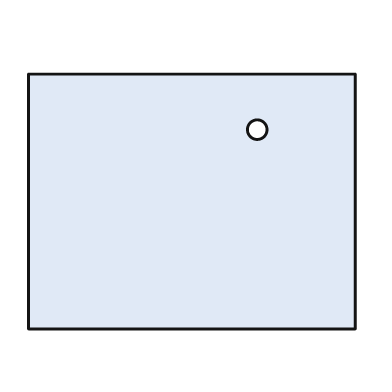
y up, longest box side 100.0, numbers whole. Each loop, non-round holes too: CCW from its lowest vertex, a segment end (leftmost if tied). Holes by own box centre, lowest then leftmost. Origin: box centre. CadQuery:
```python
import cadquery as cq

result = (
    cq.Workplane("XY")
    .moveTo(-50.0, -39.0)
    .lineTo(50.0, -39.0)
    .lineTo(50.0, 39.0)
    .lineTo(-50.0, 39.0)
    .close()
    .moveTo(20.0, 22.0)
    .circle(3.0)
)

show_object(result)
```